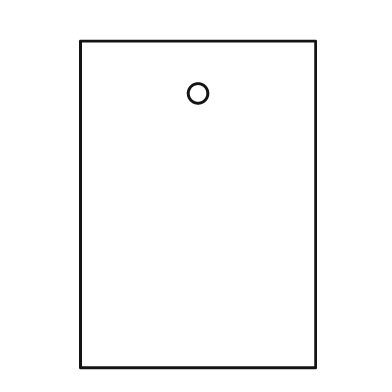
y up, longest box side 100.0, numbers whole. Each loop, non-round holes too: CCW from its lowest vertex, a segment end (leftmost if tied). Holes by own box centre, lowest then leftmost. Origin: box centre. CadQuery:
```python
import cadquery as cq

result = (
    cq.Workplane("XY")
    .moveTo(-36.0, -50.0)
    .lineTo(36.0, -50.0)
    .lineTo(36.0, 50.0)
    .lineTo(-36.0, 50.0)
    .close()
    .moveTo(0.0, 34.0)
    .circle(3.0)
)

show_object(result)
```